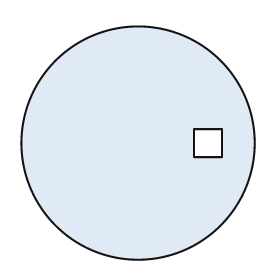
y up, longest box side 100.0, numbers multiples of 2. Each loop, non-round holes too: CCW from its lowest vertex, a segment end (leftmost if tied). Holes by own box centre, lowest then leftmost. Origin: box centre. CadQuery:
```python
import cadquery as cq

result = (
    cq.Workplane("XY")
    .moveTo(0.0, 0.0)
    .circle(50.0)
    .moveTo(24.0, -6.0)
    .lineTo(36.0, -6.0)
    .lineTo(36.0, 6.0)
    .lineTo(24.0, 6.0)
    .close()
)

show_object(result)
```